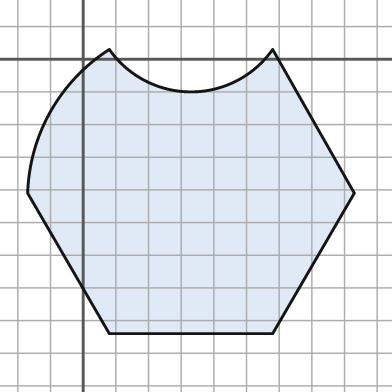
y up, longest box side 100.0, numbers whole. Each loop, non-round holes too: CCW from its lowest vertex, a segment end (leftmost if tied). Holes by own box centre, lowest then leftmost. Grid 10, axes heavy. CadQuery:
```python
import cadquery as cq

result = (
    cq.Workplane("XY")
    .moveTo(8.0, -84.0)
    .lineTo(58.0, -84.0)
    .lineTo(83.0, -41.0)
    .lineTo(58.0, 3.0)
    .threePointArc((33.0, -10.0), (8.0, 3.0))
    .threePointArc((-10.0, -16.0), (-17.0, -41.0))
    .close()
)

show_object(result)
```